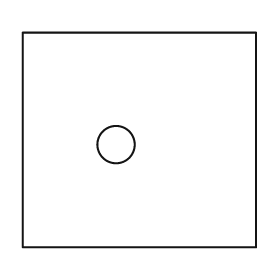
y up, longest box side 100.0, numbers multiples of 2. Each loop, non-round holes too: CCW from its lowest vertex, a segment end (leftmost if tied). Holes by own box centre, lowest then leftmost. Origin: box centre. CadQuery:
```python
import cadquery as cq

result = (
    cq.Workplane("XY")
    .moveTo(-50.0, -46.0)
    .lineTo(50.0, -46.0)
    .lineTo(50.0, 46.0)
    .lineTo(-50.0, 46.0)
    .close()
    .moveTo(-10.0, -2.0)
    .circle(8.0)
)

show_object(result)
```